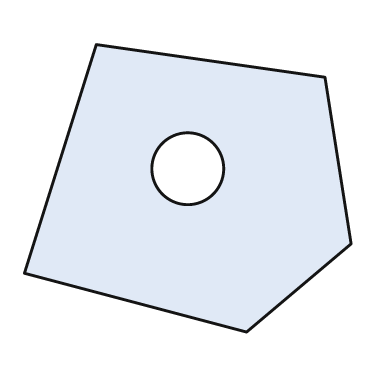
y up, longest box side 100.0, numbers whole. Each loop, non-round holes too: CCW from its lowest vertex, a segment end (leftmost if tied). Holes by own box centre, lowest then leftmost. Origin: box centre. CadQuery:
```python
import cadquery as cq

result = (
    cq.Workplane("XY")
    .moveTo(18.0, -44.0)
    .lineTo(50.0, -17.0)
    .lineTo(42.0, 34.0)
    .lineTo(-28.0, 44.0)
    .lineTo(-50.0, -26.0)
    .close()
    .moveTo(0.0, 6.0)
    .circle(11.0)
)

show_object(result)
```